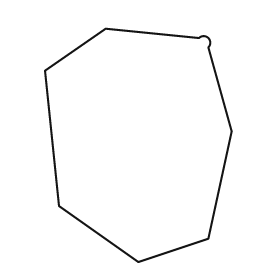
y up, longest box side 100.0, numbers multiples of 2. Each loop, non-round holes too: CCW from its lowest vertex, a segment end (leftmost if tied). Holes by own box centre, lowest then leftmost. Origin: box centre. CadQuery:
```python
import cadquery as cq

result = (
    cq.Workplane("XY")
    .moveTo(0.0, -50.0)
    .lineTo(30.0, -40.0)
    .lineTo(40.0, 6.0)
    .lineTo(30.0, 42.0)
    .threePointArc((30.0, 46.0), (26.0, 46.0))
    .lineTo(-14.0, 50.0)
    .lineTo(-40.0, 32.0)
    .lineTo(-34.0, -26.0)
    .close()
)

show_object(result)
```